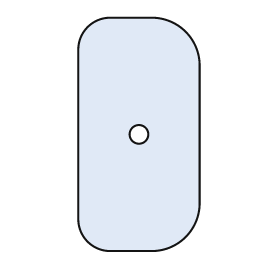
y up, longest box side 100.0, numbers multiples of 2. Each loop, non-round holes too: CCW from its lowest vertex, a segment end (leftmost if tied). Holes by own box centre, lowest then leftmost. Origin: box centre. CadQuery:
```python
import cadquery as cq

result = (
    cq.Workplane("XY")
    .moveTo(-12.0, -50.0)
    .lineTo(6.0, -50.0)
    .threePointArc((20.0, -44.0), (26.0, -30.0))
    .lineTo(26.0, 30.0)
    .threePointArc((20.0, 44.0), (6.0, 50.0))
    .lineTo(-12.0, 50.0)
    .threePointArc((-22.0, 46.0), (-26.0, 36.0))
    .lineTo(-26.0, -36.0)
    .threePointArc((-22.0, -46.0), (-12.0, -50.0))
    .close()
    .moveTo(0.0, 0.0)
    .circle(4.0)
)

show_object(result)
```